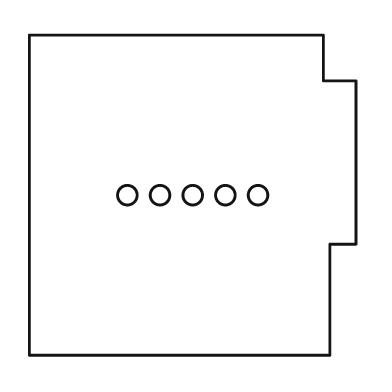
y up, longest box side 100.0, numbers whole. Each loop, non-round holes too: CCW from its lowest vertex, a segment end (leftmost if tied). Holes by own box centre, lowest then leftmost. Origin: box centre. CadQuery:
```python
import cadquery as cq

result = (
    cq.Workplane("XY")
    .moveTo(-50.0, -49.0)
    .lineTo(42.0, -49.0)
    .lineTo(42.0, -15.0)
    .lineTo(50.0, -15.0)
    .lineTo(50.0, 35.0)
    .lineTo(40.0, 35.0)
    .lineTo(40.0, 49.0)
    .lineTo(-50.0, 49.0)
    .close()
    .moveTo(-20.0, 0.0)
    .circle(3.0)
    .moveTo(-10.0, 0.0)
    .circle(3.0)
    .moveTo(0.0, 0.0)
    .circle(3.0)
    .moveTo(10.0, 0.0)
    .circle(3.0)
    .moveTo(20.0, 0.0)
    .circle(3.0)
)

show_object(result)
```